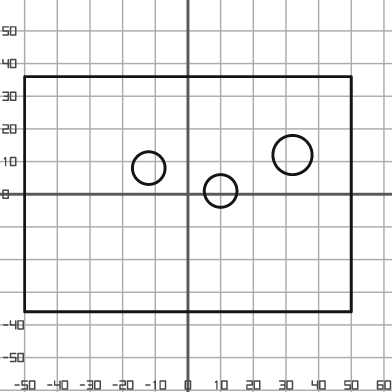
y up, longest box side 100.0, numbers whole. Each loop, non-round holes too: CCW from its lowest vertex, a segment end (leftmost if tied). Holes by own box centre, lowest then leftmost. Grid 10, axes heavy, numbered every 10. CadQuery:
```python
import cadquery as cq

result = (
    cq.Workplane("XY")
    .moveTo(-50.0, -36.0)
    .lineTo(50.0, -36.0)
    .lineTo(50.0, 36.0)
    .lineTo(-50.0, 36.0)
    .close()
    .moveTo(10.0, 1.0)
    .circle(5.0)
    .moveTo(-12.0, 8.0)
    .circle(5.0)
    .moveTo(32.0, 12.0)
    .circle(6.0)
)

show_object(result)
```